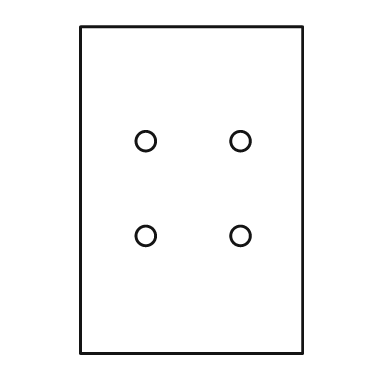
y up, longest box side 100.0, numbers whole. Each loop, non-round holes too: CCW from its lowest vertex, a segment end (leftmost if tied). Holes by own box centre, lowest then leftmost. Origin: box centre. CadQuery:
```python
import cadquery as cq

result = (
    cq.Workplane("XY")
    .moveTo(-34.0, -50.0)
    .lineTo(34.0, -50.0)
    .lineTo(34.0, 50.0)
    .lineTo(-34.0, 50.0)
    .close()
    .moveTo(-14.0, -14.0)
    .circle(3.0)
    .moveTo(15.0, -14.0)
    .circle(3.0)
    .moveTo(-14.0, 15.0)
    .circle(3.0)
    .moveTo(15.0, 15.0)
    .circle(3.0)
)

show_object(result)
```